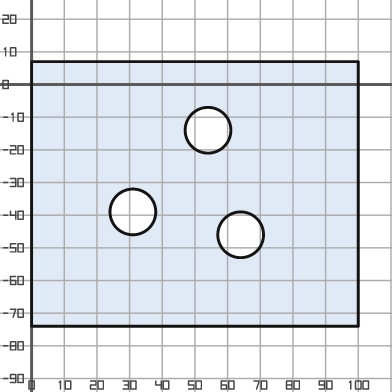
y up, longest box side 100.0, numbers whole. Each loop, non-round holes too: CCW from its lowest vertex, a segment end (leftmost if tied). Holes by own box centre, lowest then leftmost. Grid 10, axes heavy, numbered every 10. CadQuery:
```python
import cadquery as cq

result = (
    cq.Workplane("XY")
    .moveTo(0.0, -74.0)
    .lineTo(100.0, -74.0)
    .lineTo(100.0, 7.0)
    .lineTo(0.0, 7.0)
    .close()
    .moveTo(64.0, -46.0)
    .circle(7.0)
    .moveTo(31.0, -39.0)
    .circle(7.0)
    .moveTo(54.0, -14.0)
    .circle(7.0)
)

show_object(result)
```